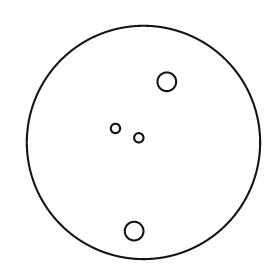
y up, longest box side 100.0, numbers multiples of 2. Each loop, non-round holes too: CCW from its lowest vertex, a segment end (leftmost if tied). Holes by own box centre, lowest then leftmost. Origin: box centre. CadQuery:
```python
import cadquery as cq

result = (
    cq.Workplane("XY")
    .moveTo(0.0, 0.0)
    .circle(50.0)
    .moveTo(-4.0, -38.0)
    .circle(4.0)
    .moveTo(-2.0, 2.0)
    .circle(2.0)
    .moveTo(-12.0, 6.0)
    .circle(2.0)
    .moveTo(10.0, 26.0)
    .circle(4.0)
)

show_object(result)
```